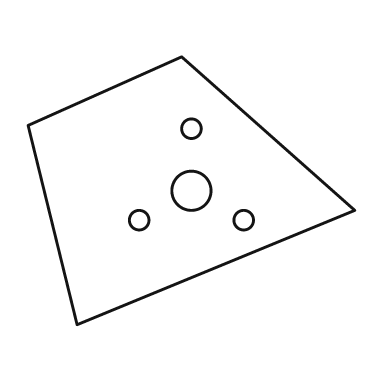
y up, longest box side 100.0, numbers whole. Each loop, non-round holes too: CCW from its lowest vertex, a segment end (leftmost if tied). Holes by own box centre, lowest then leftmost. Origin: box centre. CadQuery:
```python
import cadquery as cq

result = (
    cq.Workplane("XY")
    .moveTo(-35.0, -41.0)
    .lineTo(50.0, -6.0)
    .lineTo(-3.0, 41.0)
    .lineTo(-50.0, 20.0)
    .close()
    .moveTo(-16.0, -9.0)
    .circle(3.0)
    .moveTo(16.0, -9.0)
    .circle(3.0)
    .moveTo(0.0, 0.0)
    .circle(6.0)
    .moveTo(0.0, 19.0)
    .circle(3.0)
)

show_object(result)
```